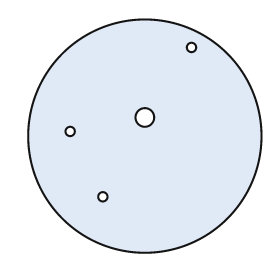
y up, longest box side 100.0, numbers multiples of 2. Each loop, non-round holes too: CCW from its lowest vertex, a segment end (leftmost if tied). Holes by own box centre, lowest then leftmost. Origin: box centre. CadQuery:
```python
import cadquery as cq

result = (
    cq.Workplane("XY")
    .moveTo(0.0, 0.0)
    .circle(50.0)
    .moveTo(-18.0, -26.0)
    .circle(2.0)
    .moveTo(-32.0, 2.0)
    .circle(2.0)
    .moveTo(0.0, 8.0)
    .circle(4.0)
    .moveTo(20.0, 38.0)
    .circle(2.0)
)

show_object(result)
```